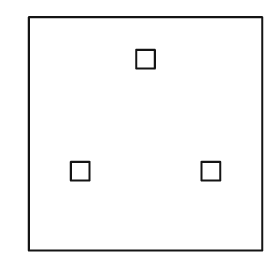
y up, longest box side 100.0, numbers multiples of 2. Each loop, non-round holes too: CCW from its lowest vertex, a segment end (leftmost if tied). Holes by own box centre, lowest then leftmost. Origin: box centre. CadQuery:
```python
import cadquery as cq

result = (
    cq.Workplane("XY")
    .moveTo(-50.0, -50.0)
    .lineTo(50.0, -50.0)
    .lineTo(50.0, 50.0)
    .lineTo(-50.0, 50.0)
    .close()
    .moveTo(-32.0, -20.0)
    .lineTo(-24.0, -20.0)
    .lineTo(-24.0, -12.0)
    .lineTo(-32.0, -12.0)
    .close()
    .moveTo(24.0, -20.0)
    .lineTo(32.0, -20.0)
    .lineTo(32.0, -12.0)
    .lineTo(24.0, -12.0)
    .close()
    .moveTo(-4.0, 28.0)
    .lineTo(4.0, 28.0)
    .lineTo(4.0, 36.0)
    .lineTo(-4.0, 36.0)
    .close()
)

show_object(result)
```